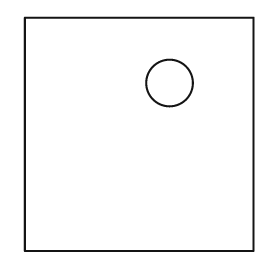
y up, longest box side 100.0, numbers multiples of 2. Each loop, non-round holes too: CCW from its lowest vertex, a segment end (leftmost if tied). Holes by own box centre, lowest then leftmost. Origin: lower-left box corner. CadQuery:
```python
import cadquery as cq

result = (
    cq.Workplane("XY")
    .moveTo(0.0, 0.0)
    .lineTo(98.0, 0.0)
    .lineTo(98.0, 100.0)
    .lineTo(0.0, 100.0)
    .close()
    .moveTo(62.0, 72.0)
    .circle(10.0)
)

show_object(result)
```